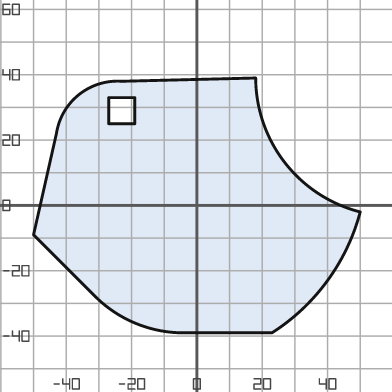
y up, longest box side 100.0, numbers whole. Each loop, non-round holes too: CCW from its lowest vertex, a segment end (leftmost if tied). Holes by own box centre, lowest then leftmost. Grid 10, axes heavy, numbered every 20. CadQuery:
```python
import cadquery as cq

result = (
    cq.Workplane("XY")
    .moveTo(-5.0, -39.0)
    .lineTo(23.0, -39.0)
    .threePointArc((40.0, -23.0), (50.0, -2.0))
    .threePointArc((27.0, 13.0), (18.0, 39.0))
    .lineTo(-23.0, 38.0)
    .threePointArc((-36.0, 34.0), (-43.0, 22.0))
    .lineTo(-50.0, -9.0)
    .lineTo(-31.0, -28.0)
    .threePointArc((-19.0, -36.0), (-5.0, -39.0))
    .close()
    .moveTo(-27.0, 25.0)
    .lineTo(-19.0, 25.0)
    .lineTo(-19.0, 33.0)
    .lineTo(-27.0, 33.0)
    .close()
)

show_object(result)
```